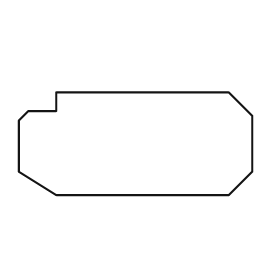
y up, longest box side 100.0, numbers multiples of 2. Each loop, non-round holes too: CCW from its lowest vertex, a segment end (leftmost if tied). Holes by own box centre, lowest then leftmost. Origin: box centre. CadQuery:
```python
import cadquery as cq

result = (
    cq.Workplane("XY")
    .moveTo(-34.0, -22.0)
    .lineTo(40.0, -22.0)
    .lineTo(50.0, -12.0)
    .lineTo(50.0, 12.0)
    .lineTo(40.0, 22.0)
    .lineTo(-34.0, 22.0)
    .lineTo(-34.0, 14.0)
    .lineTo(-46.0, 14.0)
    .lineTo(-50.0, 10.0)
    .lineTo(-50.0, -12.0)
    .close()
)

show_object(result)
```